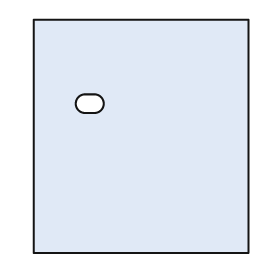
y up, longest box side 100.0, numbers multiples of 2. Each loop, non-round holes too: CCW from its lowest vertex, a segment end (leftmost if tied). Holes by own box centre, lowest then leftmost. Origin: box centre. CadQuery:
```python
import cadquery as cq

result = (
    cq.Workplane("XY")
    .moveTo(-46.0, -50.0)
    .lineTo(46.0, -50.0)
    .lineTo(46.0, 50.0)
    .lineTo(-46.0, 50.0)
    .close()
    .moveTo(-24.0, 10.0)
    .lineTo(-20.0, 10.0)
    .threePointArc((-16.0, 14.0), (-20.0, 18.0))
    .lineTo(-24.0, 18.0)
    .threePointArc((-28.0, 14.0), (-24.0, 10.0))
    .close()
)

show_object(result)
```